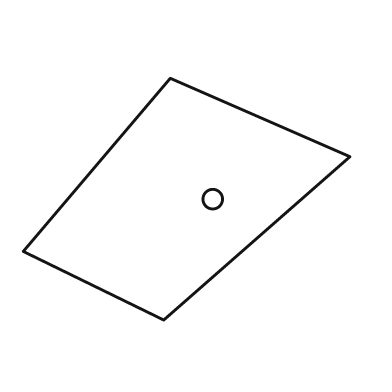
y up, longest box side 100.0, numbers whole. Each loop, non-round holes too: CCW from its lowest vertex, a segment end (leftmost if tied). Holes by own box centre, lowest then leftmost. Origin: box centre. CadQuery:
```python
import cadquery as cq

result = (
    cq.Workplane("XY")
    .moveTo(-7.0, -37.0)
    .lineTo(50.0, 13.0)
    .lineTo(-5.0, 37.0)
    .lineTo(-50.0, -16.0)
    .close()
    .moveTo(8.0, 0.0)
    .circle(3.0)
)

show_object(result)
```